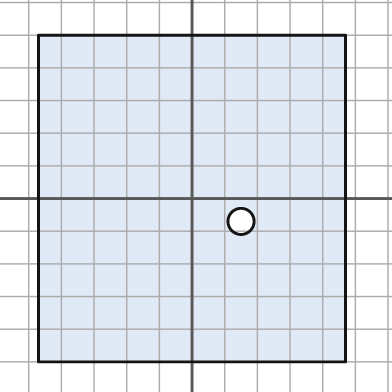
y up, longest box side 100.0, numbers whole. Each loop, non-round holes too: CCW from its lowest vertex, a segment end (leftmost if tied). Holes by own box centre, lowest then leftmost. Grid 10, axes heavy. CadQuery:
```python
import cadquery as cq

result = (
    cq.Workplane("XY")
    .moveTo(-47.0, -50.0)
    .lineTo(47.0, -50.0)
    .lineTo(47.0, 50.0)
    .lineTo(-47.0, 50.0)
    .close()
    .moveTo(15.0, -7.0)
    .circle(4.0)
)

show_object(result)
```